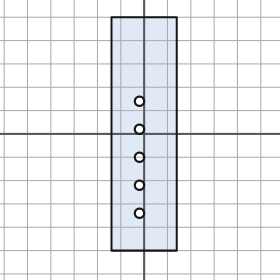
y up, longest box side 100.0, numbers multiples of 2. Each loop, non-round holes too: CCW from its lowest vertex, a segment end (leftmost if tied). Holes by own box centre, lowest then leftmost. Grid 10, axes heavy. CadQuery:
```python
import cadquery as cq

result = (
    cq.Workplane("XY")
    .moveTo(-14.0, -50.0)
    .lineTo(14.0, -50.0)
    .lineTo(14.0, 50.0)
    .lineTo(-14.0, 50.0)
    .close()
    .moveTo(-2.0, -34.0)
    .circle(2.0)
    .moveTo(-2.0, -22.0)
    .circle(2.0)
    .moveTo(-2.0, -10.0)
    .circle(2.0)
    .moveTo(-2.0, 2.0)
    .circle(2.0)
    .moveTo(-2.0, 14.0)
    .circle(2.0)
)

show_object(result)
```